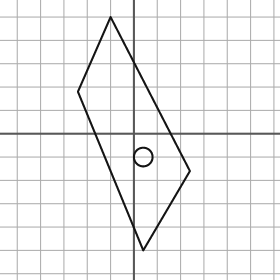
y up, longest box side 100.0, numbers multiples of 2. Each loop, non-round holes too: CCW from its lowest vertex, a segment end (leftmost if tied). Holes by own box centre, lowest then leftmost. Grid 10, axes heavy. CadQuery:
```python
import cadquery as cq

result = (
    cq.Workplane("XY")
    .moveTo(4.0, -50.0)
    .lineTo(24.0, -16.0)
    .lineTo(-10.0, 50.0)
    .lineTo(-24.0, 18.0)
    .close()
    .moveTo(4.0, -10.0)
    .circle(4.0)
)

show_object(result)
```